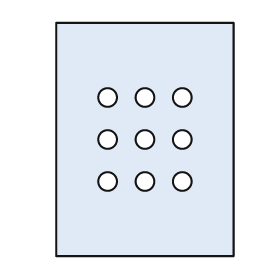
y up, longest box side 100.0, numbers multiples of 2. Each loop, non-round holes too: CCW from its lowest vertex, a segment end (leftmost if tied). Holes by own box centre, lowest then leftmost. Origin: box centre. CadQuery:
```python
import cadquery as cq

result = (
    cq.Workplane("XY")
    .moveTo(-38.0, -50.0)
    .lineTo(38.0, -50.0)
    .lineTo(38.0, 50.0)
    .lineTo(-38.0, 50.0)
    .close()
    .moveTo(-16.0, -18.0)
    .circle(4.0)
    .moveTo(0.0, -18.0)
    .circle(4.0)
    .moveTo(16.0, -18.0)
    .circle(4.0)
    .moveTo(-16.0, 0.0)
    .circle(4.0)
    .moveTo(0.0, 0.0)
    .circle(4.0)
    .moveTo(16.0, 0.0)
    .circle(4.0)
    .moveTo(-16.0, 18.0)
    .circle(4.0)
    .moveTo(0.0, 18.0)
    .circle(4.0)
    .moveTo(16.0, 18.0)
    .circle(4.0)
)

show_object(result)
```